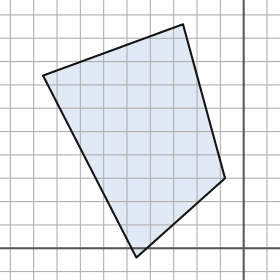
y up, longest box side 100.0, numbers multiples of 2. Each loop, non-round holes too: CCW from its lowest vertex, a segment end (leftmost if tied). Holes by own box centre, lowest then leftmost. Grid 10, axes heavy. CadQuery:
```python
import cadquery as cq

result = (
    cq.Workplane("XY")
    .moveTo(-46.0, -4.0)
    .lineTo(-8.0, 30.0)
    .lineTo(-26.0, 96.0)
    .lineTo(-86.0, 74.0)
    .close()
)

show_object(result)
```